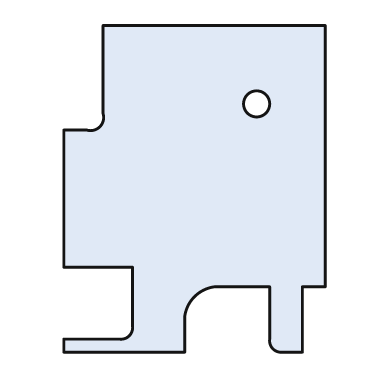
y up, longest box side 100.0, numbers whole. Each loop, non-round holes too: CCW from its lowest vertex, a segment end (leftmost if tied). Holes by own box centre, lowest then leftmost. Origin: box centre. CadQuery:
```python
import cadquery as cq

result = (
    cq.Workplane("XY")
    .moveTo(-40.0, -50.0)
    .lineTo(-3.0, -50.0)
    .lineTo(-3.0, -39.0)
    .threePointArc((0.0, -33.0), (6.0, -30.0))
    .lineTo(23.0, -30.0)
    .lineTo(23.0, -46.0)
    .threePointArc((24.0, -49.0), (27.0, -50.0))
    .lineTo(33.0, -50.0)
    .lineTo(33.0, -30.0)
    .lineTo(40.0, -30.0)
    .lineTo(40.0, 50.0)
    .lineTo(-28.0, 50.0)
    .lineTo(-28.0, 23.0)
    .threePointArc((-29.0, 19.0), (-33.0, 18.0))
    .lineTo(-40.0, 18.0)
    .lineTo(-40.0, -24.0)
    .lineTo(-19.0, -24.0)
    .lineTo(-19.0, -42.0)
    .threePointArc((-20.0, -45.0), (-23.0, -46.0))
    .lineTo(-40.0, -46.0)
    .close()
    .moveTo(19.0, 26.0)
    .circle(4.0)
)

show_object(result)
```